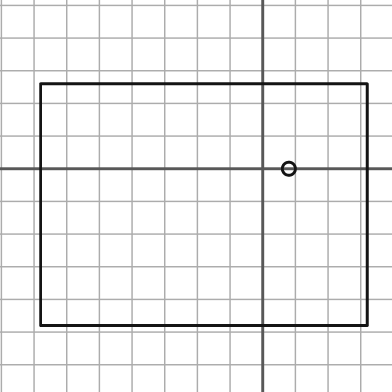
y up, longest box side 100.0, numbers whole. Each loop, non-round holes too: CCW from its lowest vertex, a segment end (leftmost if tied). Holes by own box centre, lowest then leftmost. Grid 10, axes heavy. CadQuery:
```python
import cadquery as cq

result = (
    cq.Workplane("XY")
    .moveTo(-68.0, -48.0)
    .lineTo(32.0, -48.0)
    .lineTo(32.0, 26.0)
    .lineTo(-68.0, 26.0)
    .close()
    .moveTo(8.0, 0.0)
    .circle(2.0)
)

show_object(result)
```